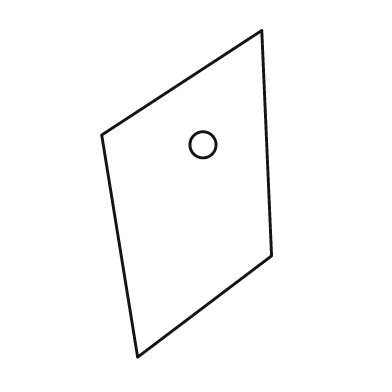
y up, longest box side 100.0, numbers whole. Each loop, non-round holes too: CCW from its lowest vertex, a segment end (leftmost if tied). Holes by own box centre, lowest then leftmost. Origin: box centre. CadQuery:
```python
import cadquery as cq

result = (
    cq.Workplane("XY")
    .moveTo(-15.0, -50.0)
    .lineTo(26.0, -19.0)
    .lineTo(23.0, 50.0)
    .lineTo(-26.0, 18.0)
    .close()
    .moveTo(5.0, 15.0)
    .circle(4.0)
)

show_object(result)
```